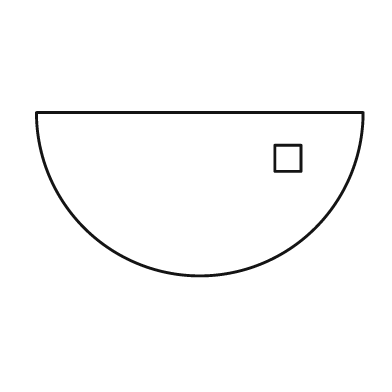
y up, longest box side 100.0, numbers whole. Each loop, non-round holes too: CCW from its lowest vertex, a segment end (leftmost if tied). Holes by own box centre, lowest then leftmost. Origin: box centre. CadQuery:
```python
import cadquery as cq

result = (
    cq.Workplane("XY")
    .moveTo(-50.0, 25.0)
    .threePointArc((0.0, -25.0), (50.0, 25.0))
    .close()
    .moveTo(23.0, 7.0)
    .lineTo(31.0, 7.0)
    .lineTo(31.0, 15.0)
    .lineTo(23.0, 15.0)
    .close()
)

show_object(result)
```